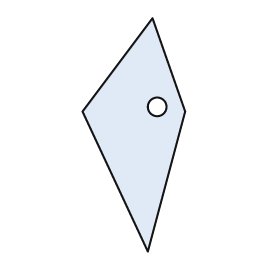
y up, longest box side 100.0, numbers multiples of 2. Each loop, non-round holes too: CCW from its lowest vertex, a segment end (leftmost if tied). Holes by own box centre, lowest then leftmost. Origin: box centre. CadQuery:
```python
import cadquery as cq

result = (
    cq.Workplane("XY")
    .moveTo(6.0, -50.0)
    .lineTo(22.0, 10.0)
    .lineTo(8.0, 50.0)
    .lineTo(-22.0, 10.0)
    .close()
    .moveTo(10.0, 12.0)
    .circle(4.0)
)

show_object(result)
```